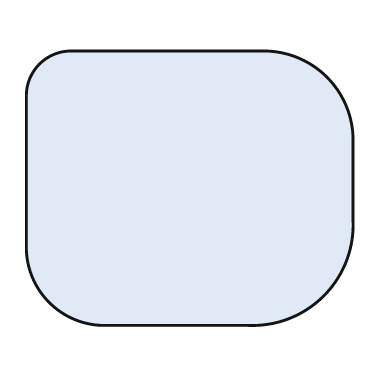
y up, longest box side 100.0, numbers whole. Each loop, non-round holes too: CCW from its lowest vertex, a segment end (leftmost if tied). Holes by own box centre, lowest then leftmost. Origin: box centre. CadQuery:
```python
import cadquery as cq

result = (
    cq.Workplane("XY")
    .moveTo(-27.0, -42.0)
    .lineTo(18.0, -42.0)
    .threePointArc((41.0, -33.0), (50.0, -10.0))
    .lineTo(50.0, 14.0)
    .threePointArc((42.0, 34.0), (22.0, 42.0))
    .lineTo(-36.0, 42.0)
    .threePointArc((-46.0, 38.0), (-50.0, 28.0))
    .lineTo(-50.0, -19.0)
    .threePointArc((-43.0, -35.0), (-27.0, -42.0))
    .close()
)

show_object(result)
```